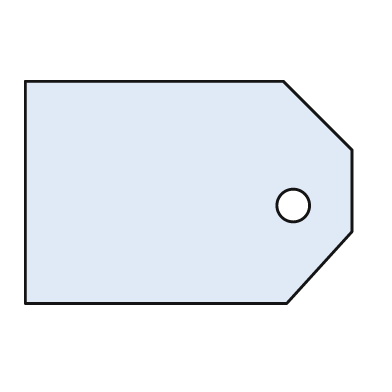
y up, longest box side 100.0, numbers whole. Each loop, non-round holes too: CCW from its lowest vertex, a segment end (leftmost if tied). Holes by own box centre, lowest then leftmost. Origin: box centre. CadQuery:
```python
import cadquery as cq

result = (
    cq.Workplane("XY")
    .moveTo(-50.0, -34.0)
    .lineTo(30.0, -34.0)
    .lineTo(50.0, -12.0)
    .lineTo(50.0, 13.0)
    .lineTo(29.0, 34.0)
    .lineTo(-50.0, 34.0)
    .close()
    .moveTo(32.0, -4.0)
    .circle(5.0)
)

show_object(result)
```